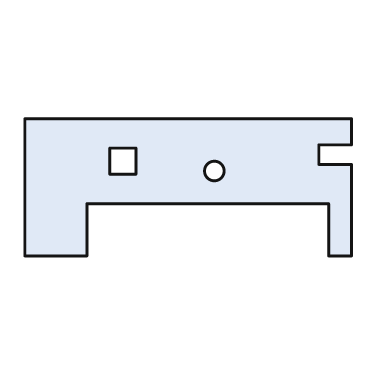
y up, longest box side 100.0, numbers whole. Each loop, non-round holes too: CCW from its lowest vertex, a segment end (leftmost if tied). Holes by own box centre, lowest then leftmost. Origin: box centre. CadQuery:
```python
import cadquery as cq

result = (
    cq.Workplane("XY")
    .moveTo(-50.0, -21.0)
    .lineTo(-31.0, -21.0)
    .lineTo(-31.0, -5.0)
    .lineTo(43.0, -5.0)
    .lineTo(43.0, -21.0)
    .lineTo(50.0, -21.0)
    .lineTo(50.0, 7.0)
    .lineTo(40.0, 7.0)
    .lineTo(40.0, 13.0)
    .lineTo(50.0, 13.0)
    .lineTo(50.0, 21.0)
    .lineTo(-50.0, 21.0)
    .close()
    .moveTo(8.0, 5.0)
    .circle(3.0)
    .moveTo(-24.0, 4.0)
    .lineTo(-16.0, 4.0)
    .lineTo(-16.0, 12.0)
    .lineTo(-24.0, 12.0)
    .close()
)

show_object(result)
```